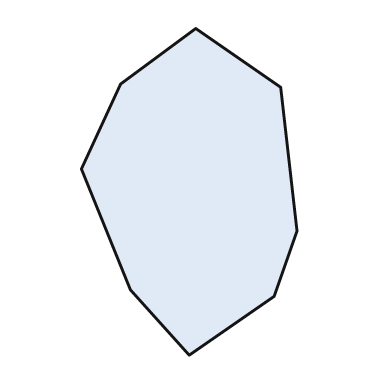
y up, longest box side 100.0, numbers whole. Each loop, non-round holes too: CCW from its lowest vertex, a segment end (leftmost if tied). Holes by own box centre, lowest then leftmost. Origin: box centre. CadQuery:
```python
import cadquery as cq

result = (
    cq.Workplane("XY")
    .moveTo(0.0, -50.0)
    .lineTo(26.0, -32.0)
    .lineTo(33.0, -12.0)
    .lineTo(28.0, 32.0)
    .lineTo(2.0, 50.0)
    .lineTo(-21.0, 33.0)
    .lineTo(-33.0, 7.0)
    .lineTo(-18.0, -30.0)
    .close()
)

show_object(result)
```